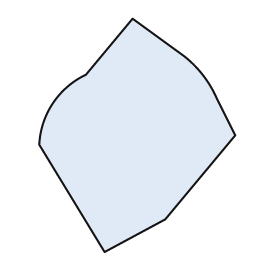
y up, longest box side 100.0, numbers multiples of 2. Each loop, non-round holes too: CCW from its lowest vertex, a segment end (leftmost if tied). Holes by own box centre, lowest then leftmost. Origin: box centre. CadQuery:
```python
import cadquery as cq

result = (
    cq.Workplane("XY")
    .moveTo(-14.0, -50.0)
    .lineTo(12.0, -36.0)
    .lineTo(42.0, 0.0)
    .lineTo(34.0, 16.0)
    .threePointArc((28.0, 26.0), (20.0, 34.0))
    .lineTo(-2.0, 50.0)
    .lineTo(-22.0, 26.0)
    .threePointArc((-36.0, 14.0), (-42.0, -4.0))
    .close()
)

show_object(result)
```